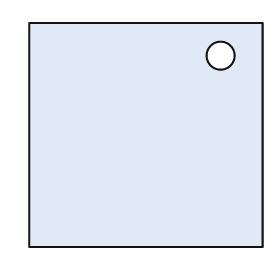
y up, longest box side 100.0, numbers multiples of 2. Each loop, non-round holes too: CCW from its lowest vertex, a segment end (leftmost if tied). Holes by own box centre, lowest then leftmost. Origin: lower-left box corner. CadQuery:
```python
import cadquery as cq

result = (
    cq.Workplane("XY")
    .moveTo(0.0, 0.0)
    .lineTo(100.0, 0.0)
    .lineTo(100.0, 96.0)
    .lineTo(0.0, 96.0)
    .close()
    .moveTo(82.0, 82.0)
    .circle(6.0)
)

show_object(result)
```